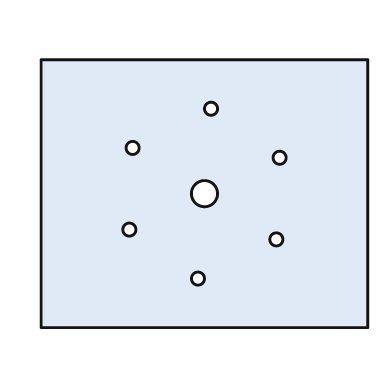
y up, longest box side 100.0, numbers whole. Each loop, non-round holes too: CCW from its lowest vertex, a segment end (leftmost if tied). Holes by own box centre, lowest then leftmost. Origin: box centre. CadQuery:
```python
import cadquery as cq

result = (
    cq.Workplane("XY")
    .moveTo(-50.0, -41.0)
    .lineTo(50.0, -41.0)
    .lineTo(50.0, 41.0)
    .lineTo(-50.0, 41.0)
    .close()
    .moveTo(-2.0, -26.0)
    .circle(2.0)
    .moveTo(22.0, -14.0)
    .circle(2.0)
    .moveTo(-23.0, -11.0)
    .circle(2.0)
    .moveTo(0.0, 0.0)
    .circle(4.0)
    .moveTo(23.0, 11.0)
    .circle(2.0)
    .moveTo(-22.0, 14.0)
    .circle(2.0)
    .moveTo(2.0, 26.0)
    .circle(2.0)
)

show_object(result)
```